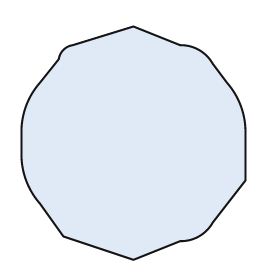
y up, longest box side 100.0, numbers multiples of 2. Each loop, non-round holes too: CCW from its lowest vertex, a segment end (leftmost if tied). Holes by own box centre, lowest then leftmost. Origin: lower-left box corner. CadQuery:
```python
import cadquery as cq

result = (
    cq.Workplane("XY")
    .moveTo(48.0, 0.0)
    .lineTo(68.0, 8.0)
    .threePointArc((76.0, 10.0), (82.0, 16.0))
    .lineTo(96.0, 34.0)
    .lineTo(96.0, 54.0)
    .threePointArc((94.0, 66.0), (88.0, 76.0))
    .lineTo(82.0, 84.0)
    .threePointArc((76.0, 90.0), (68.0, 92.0))
    .lineTo(48.0, 100.0)
    .lineTo(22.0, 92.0)
    .threePointArc((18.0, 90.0), (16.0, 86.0))
    .lineTo(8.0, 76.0)
    .threePointArc((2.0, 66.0), (0.0, 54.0))
    .lineTo(0.0, 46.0)
    .threePointArc((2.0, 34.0), (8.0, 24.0))
    .lineTo(18.0, 10.0)
    .close()
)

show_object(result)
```